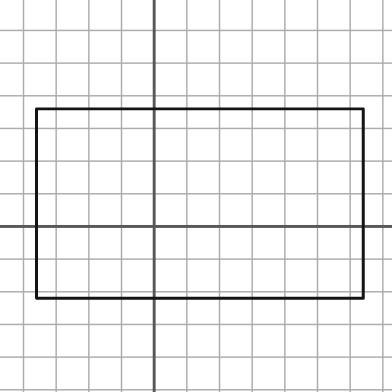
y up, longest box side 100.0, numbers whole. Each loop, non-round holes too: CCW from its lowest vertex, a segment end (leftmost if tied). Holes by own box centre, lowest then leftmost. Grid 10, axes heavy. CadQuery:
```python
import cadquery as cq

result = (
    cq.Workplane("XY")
    .moveTo(-36.0, -22.0)
    .lineTo(64.0, -22.0)
    .lineTo(64.0, 36.0)
    .lineTo(-36.0, 36.0)
    .close()
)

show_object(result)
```